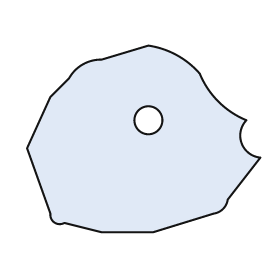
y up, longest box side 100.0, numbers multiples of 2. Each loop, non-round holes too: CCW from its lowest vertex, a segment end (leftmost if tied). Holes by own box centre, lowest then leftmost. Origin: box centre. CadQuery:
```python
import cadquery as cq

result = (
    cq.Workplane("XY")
    .moveTo(-18.0, -40.0)
    .lineTo(4.0, -40.0)
    .lineTo(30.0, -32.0)
    .threePointArc((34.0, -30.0), (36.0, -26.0))
    .lineTo(50.0, -8.0)
    .threePointArc((42.0, -2.0), (44.0, 8.0))
    .threePointArc((32.0, 16.0), (24.0, 28.0))
    .threePointArc((14.0, 36.0), (2.0, 40.0))
    .lineTo(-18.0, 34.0)
    .threePointArc((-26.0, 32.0), (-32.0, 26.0))
    .lineTo(-40.0, 18.0)
    .lineTo(-50.0, -4.0)
    .lineTo(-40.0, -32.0)
    .threePointArc((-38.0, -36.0), (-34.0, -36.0))
    .close()
    .moveTo(2.0, 8.0)
    .circle(6.0)
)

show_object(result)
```